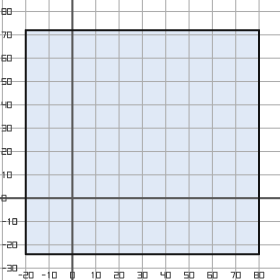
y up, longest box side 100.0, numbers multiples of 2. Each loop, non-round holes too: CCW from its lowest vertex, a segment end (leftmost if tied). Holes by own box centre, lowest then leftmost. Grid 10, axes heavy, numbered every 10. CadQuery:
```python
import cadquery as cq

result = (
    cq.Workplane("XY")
    .moveTo(-20.0, -24.0)
    .lineTo(80.0, -24.0)
    .lineTo(80.0, 72.0)
    .lineTo(-20.0, 72.0)
    .close()
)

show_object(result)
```